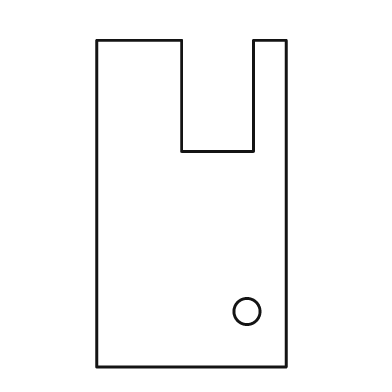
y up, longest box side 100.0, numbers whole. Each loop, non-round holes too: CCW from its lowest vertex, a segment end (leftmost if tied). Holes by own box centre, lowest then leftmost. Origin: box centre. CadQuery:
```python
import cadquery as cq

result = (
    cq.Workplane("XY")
    .moveTo(-29.0, -50.0)
    .lineTo(29.0, -50.0)
    .lineTo(29.0, 50.0)
    .lineTo(19.0, 50.0)
    .lineTo(19.0, 16.0)
    .lineTo(-3.0, 16.0)
    .lineTo(-3.0, 50.0)
    .lineTo(-29.0, 50.0)
    .close()
    .moveTo(17.0, -33.0)
    .circle(4.0)
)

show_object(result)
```